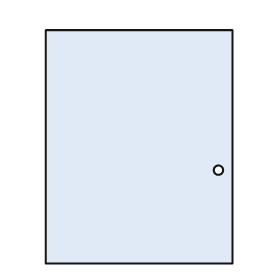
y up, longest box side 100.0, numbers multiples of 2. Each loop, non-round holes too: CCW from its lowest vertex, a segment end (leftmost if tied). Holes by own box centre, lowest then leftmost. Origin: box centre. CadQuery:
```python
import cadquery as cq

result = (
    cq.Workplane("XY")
    .moveTo(-40.0, -50.0)
    .lineTo(40.0, -50.0)
    .lineTo(40.0, 50.0)
    .lineTo(-40.0, 50.0)
    .close()
    .moveTo(34.0, -10.0)
    .circle(2.0)
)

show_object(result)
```